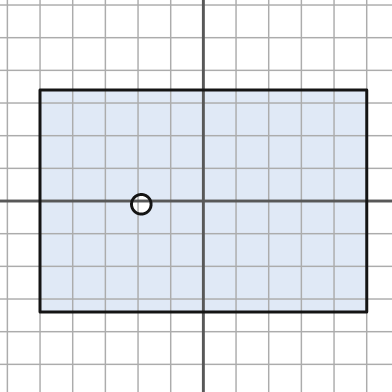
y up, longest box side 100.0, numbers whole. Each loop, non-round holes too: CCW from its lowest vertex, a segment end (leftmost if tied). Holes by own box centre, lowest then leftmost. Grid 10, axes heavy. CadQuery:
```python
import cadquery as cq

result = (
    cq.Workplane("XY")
    .moveTo(-50.0, -34.0)
    .lineTo(50.0, -34.0)
    .lineTo(50.0, 34.0)
    .lineTo(-50.0, 34.0)
    .close()
    .moveTo(-19.0, -1.0)
    .circle(3.0)
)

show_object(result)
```